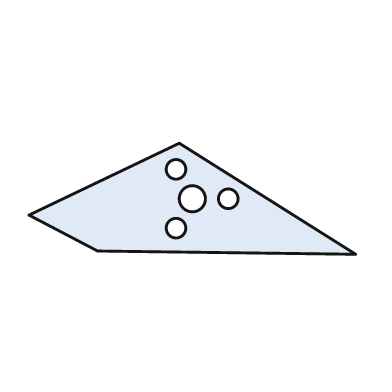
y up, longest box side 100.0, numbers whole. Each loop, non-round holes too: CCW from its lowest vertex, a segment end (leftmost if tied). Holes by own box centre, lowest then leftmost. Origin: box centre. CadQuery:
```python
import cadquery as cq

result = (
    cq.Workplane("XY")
    .moveTo(50.0, -17.0)
    .lineTo(-4.0, 17.0)
    .lineTo(-50.0, -5.0)
    .lineTo(-29.0, -16.0)
    .close()
    .moveTo(-5.0, -9.0)
    .circle(3.0)
    .moveTo(0.0, 0.0)
    .circle(4.0)
    .moveTo(11.0, 0.0)
    .circle(3.0)
    .moveTo(-5.0, 9.0)
    .circle(3.0)
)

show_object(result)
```